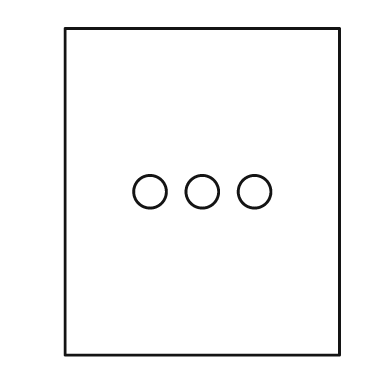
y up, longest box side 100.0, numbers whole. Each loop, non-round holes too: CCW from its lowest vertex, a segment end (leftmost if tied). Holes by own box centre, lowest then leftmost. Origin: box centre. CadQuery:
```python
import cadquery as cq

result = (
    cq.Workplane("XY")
    .moveTo(-42.0, -50.0)
    .lineTo(42.0, -50.0)
    .lineTo(42.0, 50.0)
    .lineTo(-42.0, 50.0)
    .close()
    .moveTo(-16.0, 0.0)
    .circle(5.0)
    .moveTo(0.0, 0.0)
    .circle(5.0)
    .moveTo(16.0, 0.0)
    .circle(5.0)
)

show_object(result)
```